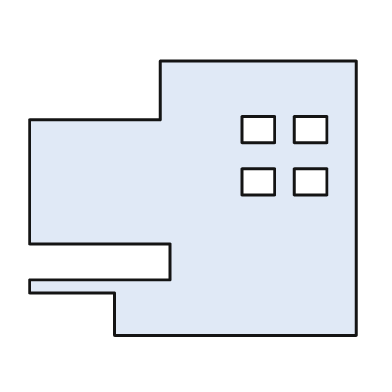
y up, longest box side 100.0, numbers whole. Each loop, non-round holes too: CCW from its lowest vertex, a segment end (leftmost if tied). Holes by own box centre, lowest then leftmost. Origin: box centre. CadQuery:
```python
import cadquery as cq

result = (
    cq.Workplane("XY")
    .moveTo(-24.0, -42.0)
    .lineTo(50.0, -42.0)
    .lineTo(50.0, 42.0)
    .lineTo(-10.0, 42.0)
    .lineTo(-10.0, 24.0)
    .lineTo(-50.0, 24.0)
    .lineTo(-50.0, -14.0)
    .lineTo(-7.0, -14.0)
    .lineTo(-7.0, -25.0)
    .lineTo(-50.0, -25.0)
    .lineTo(-50.0, -29.0)
    .lineTo(-24.0, -29.0)
    .close()
    .moveTo(15.0, 1.0)
    .lineTo(25.0, 1.0)
    .lineTo(25.0, 9.0)
    .lineTo(15.0, 9.0)
    .close()
    .moveTo(31.0, 1.0)
    .lineTo(41.0, 1.0)
    .lineTo(41.0, 9.0)
    .lineTo(31.0, 9.0)
    .close()
    .moveTo(15.0, 17.0)
    .lineTo(25.0, 17.0)
    .lineTo(25.0, 25.0)
    .lineTo(15.0, 25.0)
    .close()
    .moveTo(31.0, 17.0)
    .lineTo(41.0, 17.0)
    .lineTo(41.0, 25.0)
    .lineTo(31.0, 25.0)
    .close()
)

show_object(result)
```